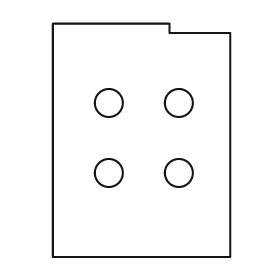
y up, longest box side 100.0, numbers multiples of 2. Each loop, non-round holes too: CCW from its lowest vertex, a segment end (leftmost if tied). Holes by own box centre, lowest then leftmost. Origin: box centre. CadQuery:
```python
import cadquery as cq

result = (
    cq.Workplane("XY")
    .moveTo(-38.0, -50.0)
    .lineTo(38.0, -50.0)
    .lineTo(38.0, 46.0)
    .lineTo(12.0, 46.0)
    .lineTo(12.0, 50.0)
    .lineTo(-38.0, 50.0)
    .close()
    .moveTo(-14.0, -14.0)
    .circle(6.0)
    .moveTo(16.0, -14.0)
    .circle(6.0)
    .moveTo(-14.0, 16.0)
    .circle(6.0)
    .moveTo(16.0, 16.0)
    .circle(6.0)
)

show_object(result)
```